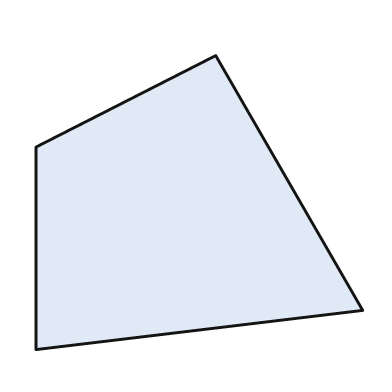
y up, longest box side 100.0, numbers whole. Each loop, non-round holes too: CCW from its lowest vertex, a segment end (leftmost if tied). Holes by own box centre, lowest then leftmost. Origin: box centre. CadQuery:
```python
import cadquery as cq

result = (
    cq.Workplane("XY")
    .moveTo(-50.0, -45.0)
    .lineTo(50.0, -33.0)
    .lineTo(5.0, 45.0)
    .lineTo(-50.0, 17.0)
    .close()
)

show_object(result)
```